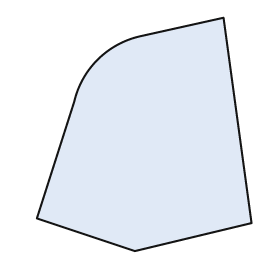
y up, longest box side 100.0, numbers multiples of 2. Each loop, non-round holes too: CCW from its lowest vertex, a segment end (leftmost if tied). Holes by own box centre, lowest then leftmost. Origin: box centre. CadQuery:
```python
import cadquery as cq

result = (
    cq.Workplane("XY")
    .moveTo(-4.0, -50.0)
    .lineTo(46.0, -38.0)
    .lineTo(34.0, 50.0)
    .lineTo(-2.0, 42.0)
    .threePointArc((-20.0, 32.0), (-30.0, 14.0))
    .lineTo(-46.0, -36.0)
    .close()
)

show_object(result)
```